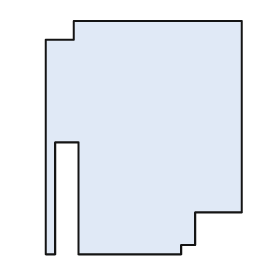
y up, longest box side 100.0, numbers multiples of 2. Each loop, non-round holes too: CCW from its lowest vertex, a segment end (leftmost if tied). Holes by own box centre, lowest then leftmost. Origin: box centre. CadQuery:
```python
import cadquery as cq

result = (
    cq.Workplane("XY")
    .moveTo(-42.0, -50.0)
    .lineTo(-38.0, -50.0)
    .lineTo(-38.0, -2.0)
    .lineTo(-28.0, -2.0)
    .lineTo(-28.0, -50.0)
    .lineTo(16.0, -50.0)
    .lineTo(16.0, -46.0)
    .lineTo(22.0, -46.0)
    .lineTo(22.0, -32.0)
    .lineTo(42.0, -32.0)
    .lineTo(42.0, 50.0)
    .lineTo(-30.0, 50.0)
    .lineTo(-30.0, 42.0)
    .lineTo(-42.0, 42.0)
    .close()
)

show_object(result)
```